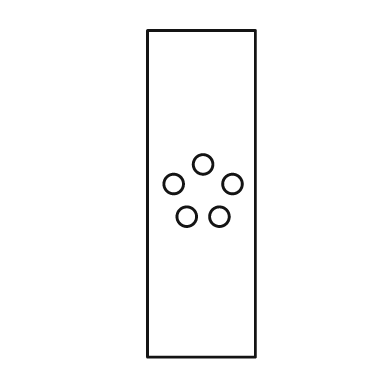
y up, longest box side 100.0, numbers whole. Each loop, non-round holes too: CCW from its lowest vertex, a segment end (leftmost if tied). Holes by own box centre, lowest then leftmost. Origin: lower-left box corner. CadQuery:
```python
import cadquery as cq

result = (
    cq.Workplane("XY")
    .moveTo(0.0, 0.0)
    .lineTo(33.0, 0.0)
    .lineTo(33.0, 100.0)
    .lineTo(0.0, 100.0)
    .close()
    .moveTo(12.0, 43.0)
    .circle(3.0)
    .moveTo(22.0, 43.0)
    .circle(3.0)
    .moveTo(8.0, 53.0)
    .circle(3.0)
    .moveTo(26.0, 53.0)
    .circle(3.0)
    .moveTo(17.0, 59.0)
    .circle(3.0)
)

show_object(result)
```